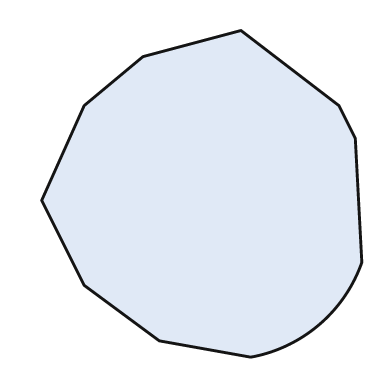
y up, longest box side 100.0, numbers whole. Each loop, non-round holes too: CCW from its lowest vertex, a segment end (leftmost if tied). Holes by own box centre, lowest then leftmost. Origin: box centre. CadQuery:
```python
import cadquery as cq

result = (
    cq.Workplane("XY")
    .moveTo(15.0, -50.0)
    .threePointArc((36.0, -40.0), (49.0, -21.0))
    .lineTo(47.0, 17.0)
    .lineTo(42.0, 27.0)
    .lineTo(12.0, 50.0)
    .lineTo(-18.0, 42.0)
    .lineTo(-36.0, 27.0)
    .lineTo(-49.0, -2.0)
    .lineTo(-36.0, -28.0)
    .lineTo(-13.0, -45.0)
    .close()
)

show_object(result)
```